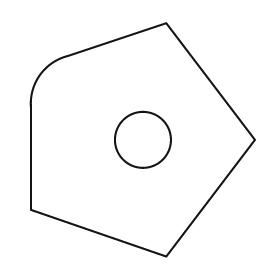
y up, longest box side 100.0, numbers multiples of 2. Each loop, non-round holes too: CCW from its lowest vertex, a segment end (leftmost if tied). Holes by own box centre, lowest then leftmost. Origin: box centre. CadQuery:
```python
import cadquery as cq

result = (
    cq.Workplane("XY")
    .moveTo(10.0, -50.0)
    .lineTo(48.0, 0.0)
    .lineTo(10.0, 50.0)
    .lineTo(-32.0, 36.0)
    .threePointArc((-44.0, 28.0), (-48.0, 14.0))
    .lineTo(-48.0, -30.0)
    .close()
    .moveTo(0.0, 0.0)
    .circle(12.0)
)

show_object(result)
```